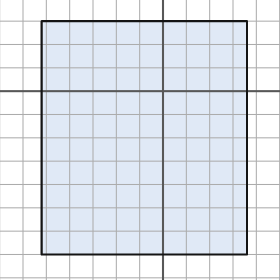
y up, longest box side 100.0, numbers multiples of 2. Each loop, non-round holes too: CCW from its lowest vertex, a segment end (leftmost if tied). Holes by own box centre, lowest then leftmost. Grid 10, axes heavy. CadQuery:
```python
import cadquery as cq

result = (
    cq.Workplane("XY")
    .moveTo(-52.0, -70.0)
    .lineTo(36.0, -70.0)
    .lineTo(36.0, 30.0)
    .lineTo(-52.0, 30.0)
    .close()
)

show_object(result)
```